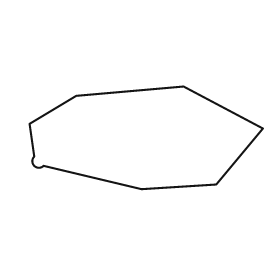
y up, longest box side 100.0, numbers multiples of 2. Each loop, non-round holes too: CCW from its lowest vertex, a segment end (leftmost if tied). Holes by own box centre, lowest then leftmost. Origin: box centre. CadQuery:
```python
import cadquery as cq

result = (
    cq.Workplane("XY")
    .moveTo(-2.0, -22.0)
    .lineTo(30.0, -20.0)
    .lineTo(50.0, 4.0)
    .lineTo(16.0, 22.0)
    .lineTo(-30.0, 18.0)
    .lineTo(-50.0, 6.0)
    .lineTo(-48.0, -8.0)
    .threePointArc((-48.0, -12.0), (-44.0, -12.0))
    .close()
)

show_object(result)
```